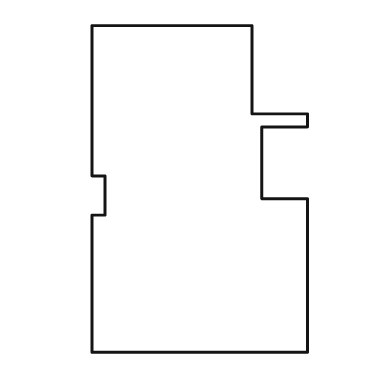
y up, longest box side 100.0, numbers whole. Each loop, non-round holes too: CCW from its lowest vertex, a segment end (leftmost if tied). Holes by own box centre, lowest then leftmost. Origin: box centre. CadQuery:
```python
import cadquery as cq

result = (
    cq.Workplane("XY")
    .moveTo(-33.0, -50.0)
    .lineTo(33.0, -50.0)
    .lineTo(33.0, -3.0)
    .lineTo(19.0, -3.0)
    .lineTo(19.0, 19.0)
    .lineTo(33.0, 19.0)
    .lineTo(33.0, 23.0)
    .lineTo(16.0, 23.0)
    .lineTo(16.0, 50.0)
    .lineTo(-33.0, 50.0)
    .lineTo(-33.0, 4.0)
    .lineTo(-29.0, 4.0)
    .lineTo(-29.0, -8.0)
    .lineTo(-33.0, -8.0)
    .close()
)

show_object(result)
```